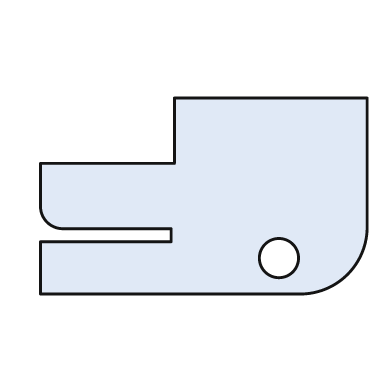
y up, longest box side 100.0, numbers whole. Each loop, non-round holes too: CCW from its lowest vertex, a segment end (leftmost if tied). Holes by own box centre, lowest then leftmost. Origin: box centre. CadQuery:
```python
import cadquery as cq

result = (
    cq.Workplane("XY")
    .moveTo(-50.0, -30.0)
    .lineTo(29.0, -30.0)
    .threePointArc((44.0, -24.0), (50.0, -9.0))
    .lineTo(50.0, 30.0)
    .lineTo(-9.0, 30.0)
    .lineTo(-9.0, 10.0)
    .lineTo(-50.0, 10.0)
    .lineTo(-50.0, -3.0)
    .threePointArc((-48.0, -8.0), (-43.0, -10.0))
    .lineTo(-10.0, -10.0)
    .lineTo(-10.0, -14.0)
    .lineTo(-50.0, -14.0)
    .close()
    .moveTo(23.0, -19.0)
    .circle(6.0)
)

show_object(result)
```